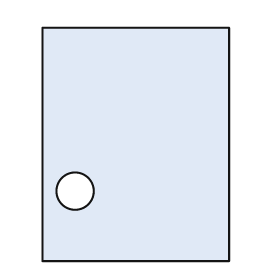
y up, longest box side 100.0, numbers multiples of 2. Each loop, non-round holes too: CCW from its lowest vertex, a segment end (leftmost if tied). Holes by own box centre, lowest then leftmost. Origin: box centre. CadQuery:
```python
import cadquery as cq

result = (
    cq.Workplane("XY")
    .moveTo(-40.0, -50.0)
    .lineTo(40.0, -50.0)
    .lineTo(40.0, 50.0)
    .lineTo(-40.0, 50.0)
    .close()
    .moveTo(-26.0, -20.0)
    .circle(8.0)
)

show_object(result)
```